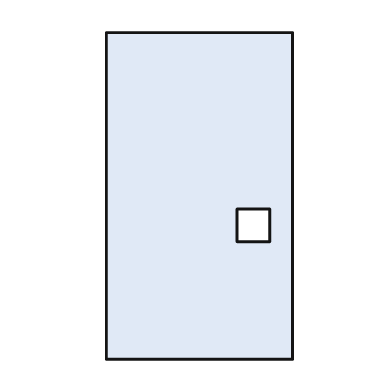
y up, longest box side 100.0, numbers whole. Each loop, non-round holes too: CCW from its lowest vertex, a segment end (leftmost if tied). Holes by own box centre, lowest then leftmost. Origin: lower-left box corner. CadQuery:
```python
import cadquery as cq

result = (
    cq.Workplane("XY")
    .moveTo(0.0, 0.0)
    .lineTo(57.0, 0.0)
    .lineTo(57.0, 100.0)
    .lineTo(0.0, 100.0)
    .close()
    .moveTo(40.0, 36.0)
    .lineTo(50.0, 36.0)
    .lineTo(50.0, 46.0)
    .lineTo(40.0, 46.0)
    .close()
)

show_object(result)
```